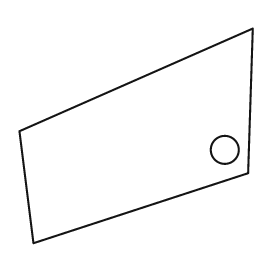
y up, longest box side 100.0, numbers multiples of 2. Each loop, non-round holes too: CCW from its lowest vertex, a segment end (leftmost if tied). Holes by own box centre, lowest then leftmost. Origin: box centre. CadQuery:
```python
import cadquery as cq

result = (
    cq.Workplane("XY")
    .moveTo(-44.0, -46.0)
    .lineTo(48.0, -16.0)
    .lineTo(50.0, 46.0)
    .lineTo(-50.0, 2.0)
    .close()
    .moveTo(38.0, -6.0)
    .circle(6.0)
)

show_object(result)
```